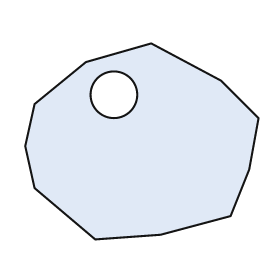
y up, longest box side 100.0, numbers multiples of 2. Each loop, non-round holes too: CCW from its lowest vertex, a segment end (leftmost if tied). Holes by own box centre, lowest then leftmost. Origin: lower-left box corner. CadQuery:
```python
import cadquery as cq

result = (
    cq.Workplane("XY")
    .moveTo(30.0, 0.0)
    .lineTo(58.0, 2.0)
    .lineTo(88.0, 10.0)
    .lineTo(96.0, 30.0)
    .lineTo(100.0, 52.0)
    .lineTo(84.0, 68.0)
    .lineTo(54.0, 84.0)
    .lineTo(26.0, 76.0)
    .lineTo(4.0, 58.0)
    .lineTo(0.0, 40.0)
    .lineTo(4.0, 22.0)
    .close()
    .moveTo(38.0, 62.0)
    .circle(10.0)
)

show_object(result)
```